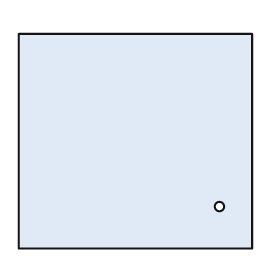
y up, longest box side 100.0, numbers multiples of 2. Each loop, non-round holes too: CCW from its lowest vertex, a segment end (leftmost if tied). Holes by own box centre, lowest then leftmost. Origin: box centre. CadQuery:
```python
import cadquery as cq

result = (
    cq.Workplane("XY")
    .moveTo(-50.0, -46.0)
    .lineTo(50.0, -46.0)
    .lineTo(50.0, 46.0)
    .lineTo(-50.0, 46.0)
    .close()
    .moveTo(36.0, -28.0)
    .circle(2.0)
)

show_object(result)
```